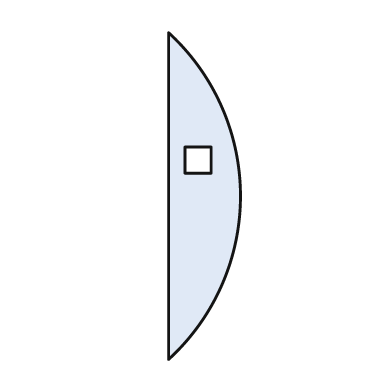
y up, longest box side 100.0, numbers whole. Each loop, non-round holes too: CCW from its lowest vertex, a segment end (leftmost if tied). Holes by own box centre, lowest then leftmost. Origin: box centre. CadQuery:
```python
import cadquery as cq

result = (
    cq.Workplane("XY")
    .moveTo(-11.0, -50.0)
    .threePointArc((11.0, 0.0), (-11.0, 50.0))
    .close()
    .moveTo(-6.0, 7.0)
    .lineTo(2.0, 7.0)
    .lineTo(2.0, 15.0)
    .lineTo(-6.0, 15.0)
    .close()
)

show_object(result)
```